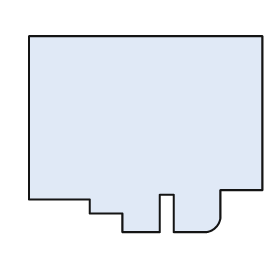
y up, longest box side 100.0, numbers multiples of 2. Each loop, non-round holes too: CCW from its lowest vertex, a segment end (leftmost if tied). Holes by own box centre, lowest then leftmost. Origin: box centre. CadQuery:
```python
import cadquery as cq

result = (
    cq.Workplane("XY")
    .moveTo(-10.0, -42.0)
    .lineTo(6.0, -42.0)
    .lineTo(6.0, -26.0)
    .lineTo(12.0, -26.0)
    .lineTo(12.0, -42.0)
    .lineTo(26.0, -42.0)
    .threePointArc((30.0, -40.0), (32.0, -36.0))
    .lineTo(32.0, -24.0)
    .lineTo(50.0, -24.0)
    .lineTo(50.0, 42.0)
    .lineTo(-50.0, 42.0)
    .lineTo(-50.0, -28.0)
    .lineTo(-24.0, -28.0)
    .lineTo(-24.0, -34.0)
    .lineTo(-10.0, -34.0)
    .close()
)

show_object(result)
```